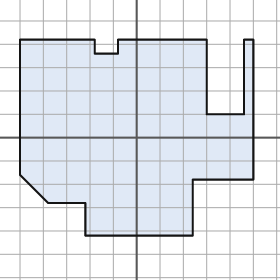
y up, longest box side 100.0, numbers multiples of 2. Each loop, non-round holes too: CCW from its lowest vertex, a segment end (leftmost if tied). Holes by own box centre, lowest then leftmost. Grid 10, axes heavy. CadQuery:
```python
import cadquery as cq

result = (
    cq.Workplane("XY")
    .moveTo(-22.0, -42.0)
    .lineTo(24.0, -42.0)
    .lineTo(24.0, -18.0)
    .lineTo(50.0, -18.0)
    .lineTo(50.0, 42.0)
    .lineTo(46.0, 42.0)
    .lineTo(46.0, 10.0)
    .lineTo(30.0, 10.0)
    .lineTo(30.0, 42.0)
    .lineTo(-8.0, 42.0)
    .lineTo(-8.0, 36.0)
    .lineTo(-18.0, 36.0)
    .lineTo(-18.0, 42.0)
    .lineTo(-50.0, 42.0)
    .lineTo(-50.0, -16.0)
    .lineTo(-38.0, -28.0)
    .lineTo(-22.0, -28.0)
    .close()
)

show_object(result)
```